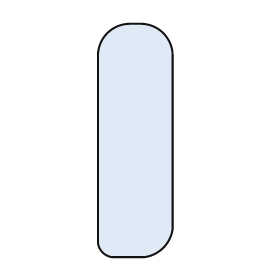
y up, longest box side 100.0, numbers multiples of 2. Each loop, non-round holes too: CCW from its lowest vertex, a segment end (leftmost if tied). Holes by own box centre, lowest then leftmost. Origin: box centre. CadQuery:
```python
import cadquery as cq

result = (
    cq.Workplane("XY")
    .moveTo(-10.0, -50.0)
    .lineTo(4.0, -50.0)
    .threePointArc((12.0, -46.0), (16.0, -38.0))
    .lineTo(16.0, 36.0)
    .threePointArc((12.0, 46.0), (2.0, 50.0))
    .lineTo(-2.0, 50.0)
    .threePointArc((-12.0, 46.0), (-16.0, 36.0))
    .lineTo(-16.0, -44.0)
    .threePointArc((-14.0, -48.0), (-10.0, -50.0))
    .close()
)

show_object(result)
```